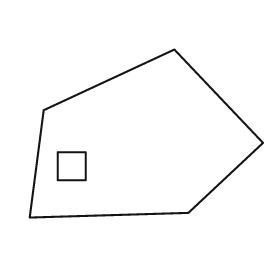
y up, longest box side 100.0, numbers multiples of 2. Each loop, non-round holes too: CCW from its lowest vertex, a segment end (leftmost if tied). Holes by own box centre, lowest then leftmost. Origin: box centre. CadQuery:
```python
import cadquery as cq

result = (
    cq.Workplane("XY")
    .moveTo(-50.0, -36.0)
    .lineTo(18.0, -34.0)
    .lineTo(50.0, -4.0)
    .lineTo(12.0, 36.0)
    .lineTo(-44.0, 10.0)
    .close()
    .moveTo(-38.0, -20.0)
    .lineTo(-26.0, -20.0)
    .lineTo(-26.0, -8.0)
    .lineTo(-38.0, -8.0)
    .close()
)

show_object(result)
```